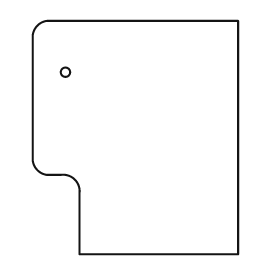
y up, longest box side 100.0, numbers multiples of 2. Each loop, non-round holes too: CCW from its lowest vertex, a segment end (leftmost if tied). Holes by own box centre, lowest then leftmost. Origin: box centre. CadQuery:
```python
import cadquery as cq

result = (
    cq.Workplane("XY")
    .moveTo(-24.0, -50.0)
    .lineTo(44.0, -50.0)
    .lineTo(44.0, 50.0)
    .lineTo(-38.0, 50.0)
    .threePointArc((-42.0, 48.0), (-44.0, 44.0))
    .lineTo(-44.0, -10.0)
    .threePointArc((-42.0, -14.0), (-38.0, -16.0))
    .lineTo(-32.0, -16.0)
    .threePointArc((-26.0, -18.0), (-24.0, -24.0))
    .close()
    .moveTo(-30.0, 28.0)
    .circle(2.0)
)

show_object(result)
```